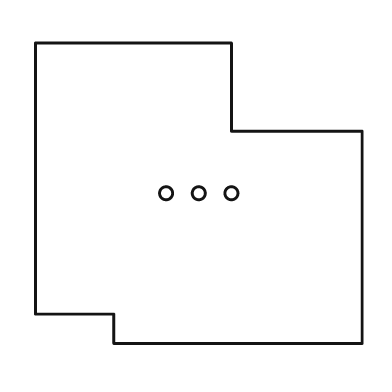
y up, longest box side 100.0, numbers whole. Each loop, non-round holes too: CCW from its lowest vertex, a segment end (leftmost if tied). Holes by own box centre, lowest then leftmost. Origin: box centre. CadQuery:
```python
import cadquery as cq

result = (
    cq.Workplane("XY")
    .moveTo(-26.0, -46.0)
    .lineTo(50.0, -46.0)
    .lineTo(50.0, 19.0)
    .lineTo(10.0, 19.0)
    .lineTo(10.0, 46.0)
    .lineTo(-50.0, 46.0)
    .lineTo(-50.0, -37.0)
    .lineTo(-26.0, -37.0)
    .close()
    .moveTo(-10.0, 0.0)
    .circle(2.0)
    .moveTo(0.0, 0.0)
    .circle(2.0)
    .moveTo(10.0, 0.0)
    .circle(2.0)
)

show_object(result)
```